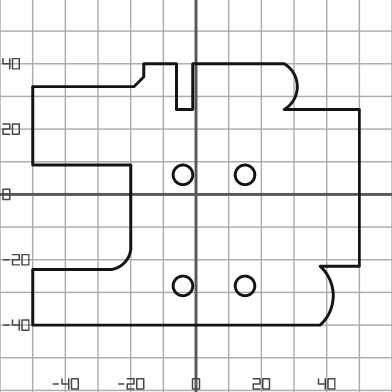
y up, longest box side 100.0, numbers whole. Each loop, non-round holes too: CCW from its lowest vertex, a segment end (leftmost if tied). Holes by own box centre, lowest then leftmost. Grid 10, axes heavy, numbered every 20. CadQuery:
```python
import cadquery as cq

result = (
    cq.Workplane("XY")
    .moveTo(-50.0, -40.0)
    .lineTo(38.0, -40.0)
    .threePointArc((42.0, -31.0), (38.0, -22.0))
    .lineTo(50.0, -22.0)
    .lineTo(50.0, 26.0)
    .lineTo(27.0, 26.0)
    .threePointArc((31.0, 33.0), (27.0, 40.0))
    .lineTo(-1.0, 40.0)
    .lineTo(-1.0, 26.0)
    .lineTo(-6.0, 26.0)
    .lineTo(-6.0, 40.0)
    .lineTo(-16.0, 40.0)
    .lineTo(-16.0, 36.0)
    .lineTo(-19.0, 33.0)
    .lineTo(-50.0, 33.0)
    .lineTo(-50.0, 9.0)
    .lineTo(-20.0, 9.0)
    .lineTo(-20.0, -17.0)
    .threePointArc((-22.0, -21.0), (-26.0, -23.0))
    .lineTo(-50.0, -23.0)
    .close()
    .moveTo(-4.0, -28.0)
    .circle(3.0)
    .moveTo(15.0, -28.0)
    .circle(3.0)
    .moveTo(-4.0, 6.0)
    .circle(3.0)
    .moveTo(15.0, 6.0)
    .circle(3.0)
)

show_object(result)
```